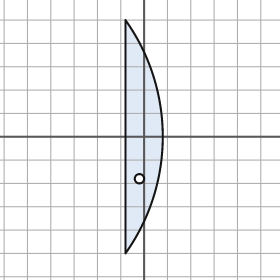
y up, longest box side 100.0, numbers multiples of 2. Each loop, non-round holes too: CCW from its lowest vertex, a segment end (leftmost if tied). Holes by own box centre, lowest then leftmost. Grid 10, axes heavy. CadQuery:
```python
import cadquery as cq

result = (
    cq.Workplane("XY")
    .moveTo(-8.0, -50.0)
    .threePointArc((8.0, 0.0), (-8.0, 50.0))
    .close()
    .moveTo(-2.0, -18.0)
    .circle(2.0)
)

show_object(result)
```